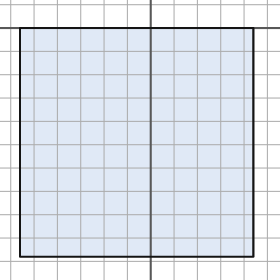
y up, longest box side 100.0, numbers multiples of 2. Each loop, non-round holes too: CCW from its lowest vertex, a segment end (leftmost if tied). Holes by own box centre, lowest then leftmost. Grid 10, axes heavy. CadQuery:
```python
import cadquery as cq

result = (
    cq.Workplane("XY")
    .moveTo(-56.0, -98.0)
    .lineTo(44.0, -98.0)
    .lineTo(44.0, 0.0)
    .lineTo(-56.0, 0.0)
    .close()
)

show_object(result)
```